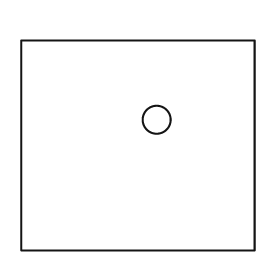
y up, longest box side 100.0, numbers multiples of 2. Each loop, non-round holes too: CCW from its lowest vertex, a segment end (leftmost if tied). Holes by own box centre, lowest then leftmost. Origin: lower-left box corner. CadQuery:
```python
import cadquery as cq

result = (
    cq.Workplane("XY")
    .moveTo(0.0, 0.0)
    .lineTo(100.0, 0.0)
    .lineTo(100.0, 90.0)
    .lineTo(0.0, 90.0)
    .close()
    .moveTo(58.0, 56.0)
    .circle(6.0)
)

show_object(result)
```